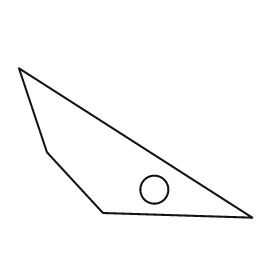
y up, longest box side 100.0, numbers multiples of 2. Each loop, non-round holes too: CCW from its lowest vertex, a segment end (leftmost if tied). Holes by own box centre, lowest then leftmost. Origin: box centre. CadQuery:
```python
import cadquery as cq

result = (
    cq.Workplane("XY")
    .moveTo(50.0, -32.0)
    .lineTo(-50.0, 32.0)
    .lineTo(-38.0, -4.0)
    .lineTo(-14.0, -30.0)
    .close()
    .moveTo(8.0, -20.0)
    .circle(6.0)
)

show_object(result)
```